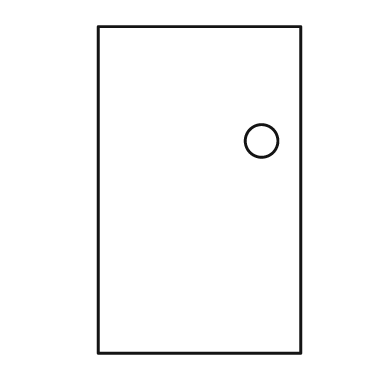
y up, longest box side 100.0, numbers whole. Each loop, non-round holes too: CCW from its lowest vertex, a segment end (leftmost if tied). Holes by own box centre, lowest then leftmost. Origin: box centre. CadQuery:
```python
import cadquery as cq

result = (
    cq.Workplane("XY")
    .moveTo(-31.0, -50.0)
    .lineTo(31.0, -50.0)
    .lineTo(31.0, 50.0)
    .lineTo(-31.0, 50.0)
    .close()
    .moveTo(19.0, 15.0)
    .circle(5.0)
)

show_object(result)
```